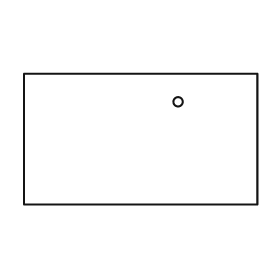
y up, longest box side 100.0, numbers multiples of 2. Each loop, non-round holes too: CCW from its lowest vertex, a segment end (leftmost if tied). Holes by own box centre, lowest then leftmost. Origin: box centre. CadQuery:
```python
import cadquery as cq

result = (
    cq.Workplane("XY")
    .moveTo(-50.0, -28.0)
    .lineTo(50.0, -28.0)
    .lineTo(50.0, 28.0)
    .lineTo(-50.0, 28.0)
    .close()
    .moveTo(16.0, 16.0)
    .circle(2.0)
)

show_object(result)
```